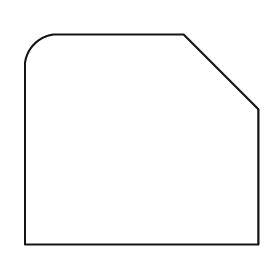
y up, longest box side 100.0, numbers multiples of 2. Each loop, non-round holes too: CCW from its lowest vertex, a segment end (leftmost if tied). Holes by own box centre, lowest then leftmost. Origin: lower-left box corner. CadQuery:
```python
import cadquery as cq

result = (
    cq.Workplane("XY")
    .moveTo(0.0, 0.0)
    .lineTo(100.0, 0.0)
    .lineTo(100.0, 58.0)
    .lineTo(68.0, 90.0)
    .lineTo(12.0, 90.0)
    .threePointArc((4.0, 86.0), (0.0, 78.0))
    .close()
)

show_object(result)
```